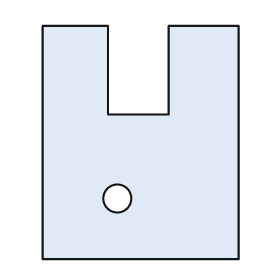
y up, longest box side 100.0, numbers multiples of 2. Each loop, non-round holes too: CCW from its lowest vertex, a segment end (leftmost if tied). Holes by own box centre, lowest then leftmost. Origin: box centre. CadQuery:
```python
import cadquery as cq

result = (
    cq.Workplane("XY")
    .moveTo(-42.0, -50.0)
    .lineTo(42.0, -50.0)
    .lineTo(42.0, 50.0)
    .lineTo(12.0, 50.0)
    .lineTo(12.0, 12.0)
    .lineTo(-14.0, 12.0)
    .lineTo(-14.0, 50.0)
    .lineTo(-42.0, 50.0)
    .close()
    .moveTo(-10.0, -24.0)
    .circle(6.0)
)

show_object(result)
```